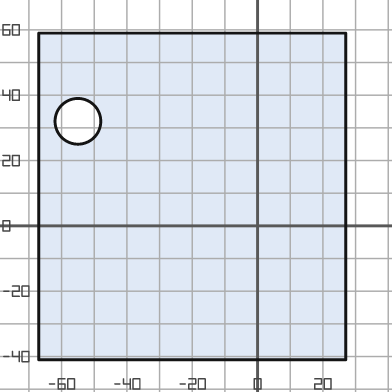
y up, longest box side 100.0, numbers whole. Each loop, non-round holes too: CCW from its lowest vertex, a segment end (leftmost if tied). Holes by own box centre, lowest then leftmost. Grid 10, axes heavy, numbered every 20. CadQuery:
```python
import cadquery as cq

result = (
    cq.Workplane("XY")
    .moveTo(-67.0, -41.0)
    .lineTo(27.0, -41.0)
    .lineTo(27.0, 59.0)
    .lineTo(-67.0, 59.0)
    .close()
    .moveTo(-55.0, 32.0)
    .circle(7.0)
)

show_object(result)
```